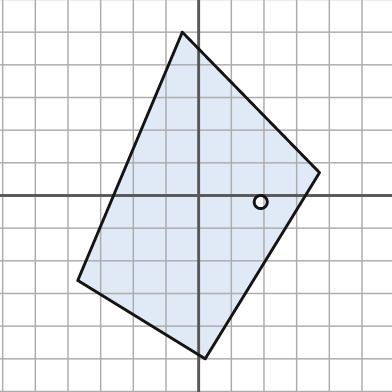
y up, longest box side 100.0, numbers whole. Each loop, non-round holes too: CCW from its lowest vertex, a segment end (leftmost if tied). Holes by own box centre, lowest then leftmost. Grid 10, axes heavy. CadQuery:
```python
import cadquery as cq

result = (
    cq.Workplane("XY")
    .moveTo(2.0, -50.0)
    .lineTo(37.0, 7.0)
    .lineTo(-5.0, 50.0)
    .lineTo(-37.0, -26.0)
    .close()
    .moveTo(19.0, -2.0)
    .circle(2.0)
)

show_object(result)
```